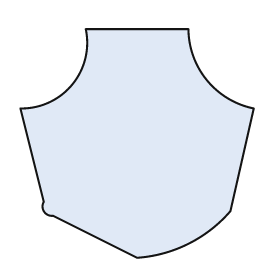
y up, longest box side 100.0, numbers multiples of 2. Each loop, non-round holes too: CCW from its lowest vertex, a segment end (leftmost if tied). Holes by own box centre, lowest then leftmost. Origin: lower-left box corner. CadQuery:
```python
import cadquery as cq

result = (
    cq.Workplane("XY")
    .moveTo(50.0, 0.0)
    .threePointArc((72.0, 6.0), (90.0, 20.0))
    .lineTo(100.0, 64.0)
    .threePointArc((80.0, 76.0), (72.0, 98.0))
    .lineTo(28.0, 98.0)
    .threePointArc((22.0, 74.0), (0.0, 64.0))
    .lineTo(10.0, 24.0)
    .threePointArc((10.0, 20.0), (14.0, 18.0))
    .close()
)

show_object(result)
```